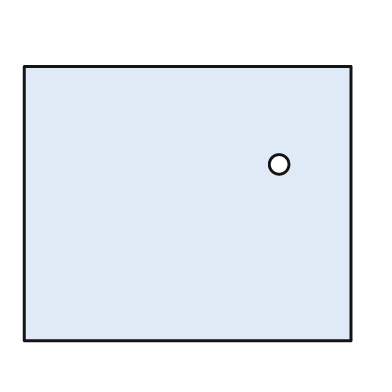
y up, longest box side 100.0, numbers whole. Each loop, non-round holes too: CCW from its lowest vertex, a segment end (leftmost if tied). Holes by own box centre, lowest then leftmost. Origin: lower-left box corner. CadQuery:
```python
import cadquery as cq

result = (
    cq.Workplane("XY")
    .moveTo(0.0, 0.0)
    .lineTo(100.0, 0.0)
    .lineTo(100.0, 84.0)
    .lineTo(0.0, 84.0)
    .close()
    .moveTo(78.0, 54.0)
    .circle(3.0)
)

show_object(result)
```